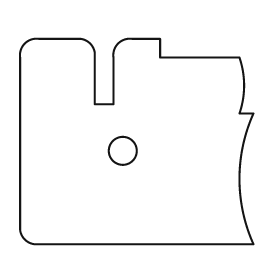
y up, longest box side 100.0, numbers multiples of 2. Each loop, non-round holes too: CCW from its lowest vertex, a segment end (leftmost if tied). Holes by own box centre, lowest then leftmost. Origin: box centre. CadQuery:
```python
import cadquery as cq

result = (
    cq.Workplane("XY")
    .moveTo(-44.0, -44.0)
    .lineTo(50.0, -44.0)
    .threePointArc((44.0, -16.0), (50.0, 12.0))
    .lineTo(44.0, 12.0)
    .threePointArc((46.0, 24.0), (44.0, 36.0))
    .lineTo(10.0, 36.0)
    .lineTo(10.0, 44.0)
    .lineTo(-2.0, 44.0)
    .threePointArc((-8.0, 42.0), (-10.0, 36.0))
    .lineTo(-10.0, 16.0)
    .lineTo(-18.0, 16.0)
    .lineTo(-18.0, 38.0)
    .threePointArc((-20.0, 42.0), (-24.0, 44.0))
    .lineTo(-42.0, 44.0)
    .threePointArc((-48.0, 42.0), (-50.0, 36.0))
    .lineTo(-50.0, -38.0)
    .threePointArc((-48.0, -42.0), (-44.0, -44.0))
    .close()
    .moveTo(-6.0, -4.0)
    .circle(6.0)
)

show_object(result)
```